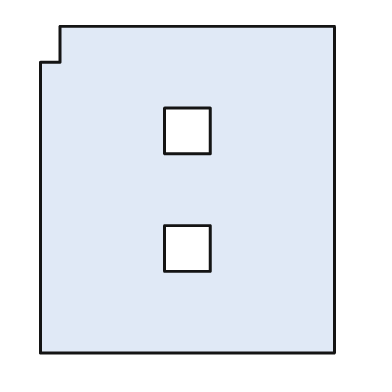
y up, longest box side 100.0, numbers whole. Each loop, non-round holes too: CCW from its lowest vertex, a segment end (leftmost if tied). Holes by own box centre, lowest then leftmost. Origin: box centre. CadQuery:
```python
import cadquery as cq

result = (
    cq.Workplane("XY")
    .moveTo(-45.0, -50.0)
    .lineTo(45.0, -50.0)
    .lineTo(45.0, 50.0)
    .lineTo(-39.0, 50.0)
    .lineTo(-39.0, 39.0)
    .lineTo(-45.0, 39.0)
    .close()
    .moveTo(-7.0, -25.0)
    .lineTo(7.0, -25.0)
    .lineTo(7.0, -11.0)
    .lineTo(-7.0, -11.0)
    .close()
    .moveTo(-7.0, 11.0)
    .lineTo(7.0, 11.0)
    .lineTo(7.0, 25.0)
    .lineTo(-7.0, 25.0)
    .close()
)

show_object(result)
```